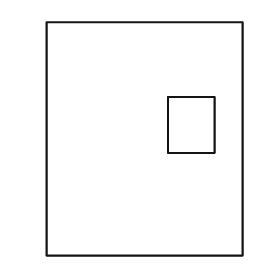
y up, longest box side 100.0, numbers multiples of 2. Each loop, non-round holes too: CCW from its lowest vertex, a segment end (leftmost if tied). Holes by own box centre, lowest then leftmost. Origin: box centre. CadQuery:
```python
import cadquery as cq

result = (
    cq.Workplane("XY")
    .moveTo(-42.0, -50.0)
    .lineTo(42.0, -50.0)
    .lineTo(42.0, 50.0)
    .lineTo(-42.0, 50.0)
    .close()
    .moveTo(10.0, -6.0)
    .lineTo(30.0, -6.0)
    .lineTo(30.0, 18.0)
    .lineTo(10.0, 18.0)
    .close()
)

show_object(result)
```